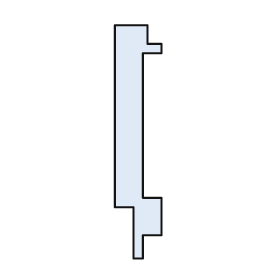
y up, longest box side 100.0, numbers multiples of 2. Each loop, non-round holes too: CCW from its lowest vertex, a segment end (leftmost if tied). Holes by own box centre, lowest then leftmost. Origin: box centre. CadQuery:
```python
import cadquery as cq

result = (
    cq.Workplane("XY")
    .moveTo(-2.0, -50.0)
    .lineTo(2.0, -50.0)
    .lineTo(2.0, -40.0)
    .lineTo(10.0, -40.0)
    .lineTo(10.0, -24.0)
    .lineTo(2.0, -24.0)
    .lineTo(2.0, 38.0)
    .lineTo(10.0, 38.0)
    .lineTo(10.0, 42.0)
    .lineTo(4.0, 42.0)
    .lineTo(4.0, 50.0)
    .lineTo(-10.0, 50.0)
    .lineTo(-10.0, -28.0)
    .lineTo(-2.0, -28.0)
    .close()
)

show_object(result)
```